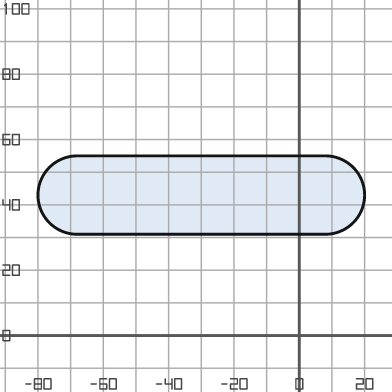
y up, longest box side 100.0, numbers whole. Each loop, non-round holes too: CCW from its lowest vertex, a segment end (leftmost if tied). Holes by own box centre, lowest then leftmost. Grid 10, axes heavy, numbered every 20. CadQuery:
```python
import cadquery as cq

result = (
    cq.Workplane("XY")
    .moveTo(-68.0, 31.0)
    .lineTo(8.0, 31.0)
    .threePointArc((20.0, 43.0), (8.0, 55.0))
    .lineTo(-68.0, 55.0)
    .threePointArc((-80.0, 43.0), (-68.0, 31.0))
    .close()
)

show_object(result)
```